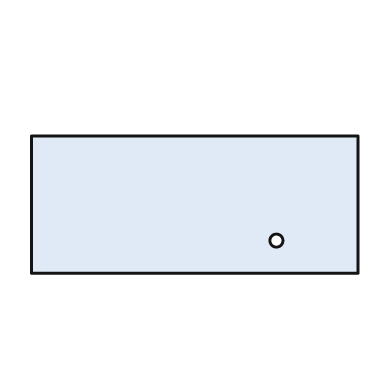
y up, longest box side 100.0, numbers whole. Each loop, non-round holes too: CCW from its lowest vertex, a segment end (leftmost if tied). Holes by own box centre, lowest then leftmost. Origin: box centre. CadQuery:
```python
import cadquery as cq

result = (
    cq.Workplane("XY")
    .moveTo(-50.0, -21.0)
    .lineTo(50.0, -21.0)
    .lineTo(50.0, 21.0)
    .lineTo(-50.0, 21.0)
    .close()
    .moveTo(25.0, -11.0)
    .circle(2.0)
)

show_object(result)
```